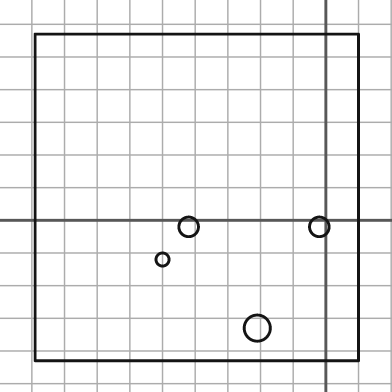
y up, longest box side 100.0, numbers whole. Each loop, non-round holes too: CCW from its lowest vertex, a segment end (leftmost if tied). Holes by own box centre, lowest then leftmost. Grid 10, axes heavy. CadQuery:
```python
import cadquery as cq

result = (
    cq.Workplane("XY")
    .moveTo(-89.0, -43.0)
    .lineTo(10.0, -43.0)
    .lineTo(10.0, 57.0)
    .lineTo(-89.0, 57.0)
    .close()
    .moveTo(-21.0, -33.0)
    .circle(4.0)
    .moveTo(-50.0, -12.0)
    .circle(2.0)
    .moveTo(-42.0, -2.0)
    .circle(3.0)
    .moveTo(-2.0, -2.0)
    .circle(3.0)
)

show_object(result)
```